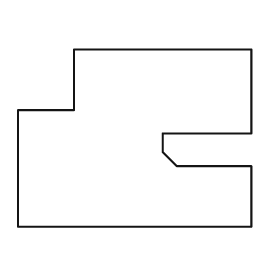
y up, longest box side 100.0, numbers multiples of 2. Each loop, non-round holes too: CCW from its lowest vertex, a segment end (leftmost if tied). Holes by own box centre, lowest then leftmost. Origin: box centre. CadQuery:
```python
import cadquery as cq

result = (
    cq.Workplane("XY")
    .moveTo(-50.0, -38.0)
    .lineTo(50.0, -38.0)
    .lineTo(50.0, -12.0)
    .lineTo(18.0, -12.0)
    .lineTo(12.0, -6.0)
    .lineTo(12.0, 2.0)
    .lineTo(50.0, 2.0)
    .lineTo(50.0, 38.0)
    .lineTo(-26.0, 38.0)
    .lineTo(-26.0, 12.0)
    .lineTo(-50.0, 12.0)
    .close()
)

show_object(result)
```